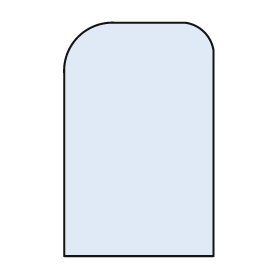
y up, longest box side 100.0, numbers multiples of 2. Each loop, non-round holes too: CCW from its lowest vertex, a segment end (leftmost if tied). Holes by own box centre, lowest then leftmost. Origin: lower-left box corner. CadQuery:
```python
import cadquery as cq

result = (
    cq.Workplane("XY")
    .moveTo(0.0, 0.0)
    .lineTo(64.0, 0.0)
    .lineTo(64.0, 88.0)
    .threePointArc((60.0, 96.0), (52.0, 100.0))
    .lineTo(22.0, 100.0)
    .threePointArc((6.0, 94.0), (0.0, 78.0))
    .close()
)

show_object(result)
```